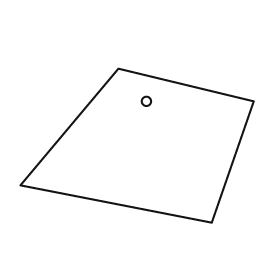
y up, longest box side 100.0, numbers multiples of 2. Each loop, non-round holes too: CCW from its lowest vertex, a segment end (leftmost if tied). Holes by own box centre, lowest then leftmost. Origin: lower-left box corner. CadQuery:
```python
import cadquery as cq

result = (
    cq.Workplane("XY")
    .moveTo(82.0, 0.0)
    .lineTo(100.0, 52.0)
    .lineTo(42.0, 66.0)
    .lineTo(0.0, 16.0)
    .close()
    .moveTo(54.0, 52.0)
    .circle(2.0)
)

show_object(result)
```